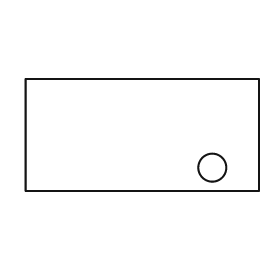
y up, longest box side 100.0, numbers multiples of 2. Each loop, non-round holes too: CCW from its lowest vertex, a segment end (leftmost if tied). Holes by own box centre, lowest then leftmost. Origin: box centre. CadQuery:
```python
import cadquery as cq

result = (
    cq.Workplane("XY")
    .moveTo(-50.0, -24.0)
    .lineTo(50.0, -24.0)
    .lineTo(50.0, 24.0)
    .lineTo(-50.0, 24.0)
    .close()
    .moveTo(30.0, -14.0)
    .circle(6.0)
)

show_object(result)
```